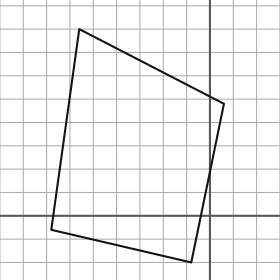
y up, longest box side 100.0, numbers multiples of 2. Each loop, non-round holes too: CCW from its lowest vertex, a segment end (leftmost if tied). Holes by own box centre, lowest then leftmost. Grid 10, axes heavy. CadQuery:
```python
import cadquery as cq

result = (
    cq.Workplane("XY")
    .moveTo(-8.0, -20.0)
    .lineTo(6.0, 48.0)
    .lineTo(-56.0, 80.0)
    .lineTo(-68.0, -6.0)
    .close()
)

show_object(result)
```